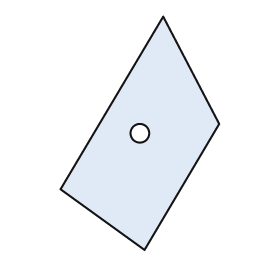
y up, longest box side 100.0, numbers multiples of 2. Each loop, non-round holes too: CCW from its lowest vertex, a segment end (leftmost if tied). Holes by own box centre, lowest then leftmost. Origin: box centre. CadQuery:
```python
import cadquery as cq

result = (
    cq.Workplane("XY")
    .moveTo(2.0, -50.0)
    .lineTo(34.0, 4.0)
    .lineTo(10.0, 50.0)
    .lineTo(-34.0, -24.0)
    .close()
    .moveTo(0.0, 0.0)
    .circle(4.0)
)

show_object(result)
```